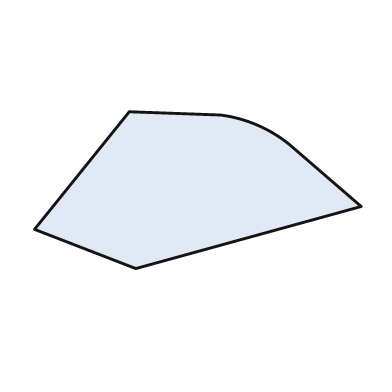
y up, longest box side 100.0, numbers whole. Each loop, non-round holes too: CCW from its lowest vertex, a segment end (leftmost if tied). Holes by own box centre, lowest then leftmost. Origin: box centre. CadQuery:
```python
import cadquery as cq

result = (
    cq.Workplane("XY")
    .moveTo(-19.0, -24.0)
    .lineTo(50.0, -5.0)
    .lineTo(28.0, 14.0)
    .threePointArc((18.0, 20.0), (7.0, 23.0))
    .lineTo(-21.0, 24.0)
    .lineTo(-50.0, -12.0)
    .close()
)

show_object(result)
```